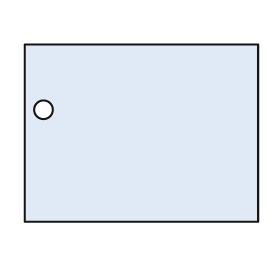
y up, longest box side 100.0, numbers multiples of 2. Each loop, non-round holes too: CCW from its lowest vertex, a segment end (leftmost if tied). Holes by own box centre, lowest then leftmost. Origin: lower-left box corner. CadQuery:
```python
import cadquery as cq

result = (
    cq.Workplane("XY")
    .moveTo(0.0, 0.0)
    .lineTo(100.0, 0.0)
    .lineTo(100.0, 76.0)
    .lineTo(0.0, 76.0)
    .close()
    .moveTo(8.0, 48.0)
    .circle(4.0)
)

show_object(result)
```